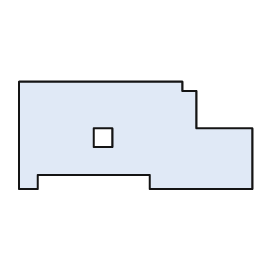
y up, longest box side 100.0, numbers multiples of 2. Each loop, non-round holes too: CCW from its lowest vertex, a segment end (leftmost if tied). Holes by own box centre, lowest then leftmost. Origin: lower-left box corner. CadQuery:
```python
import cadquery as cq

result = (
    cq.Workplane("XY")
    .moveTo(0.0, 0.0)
    .lineTo(8.0, 0.0)
    .lineTo(8.0, 6.0)
    .lineTo(56.0, 6.0)
    .lineTo(56.0, 0.0)
    .lineTo(100.0, 0.0)
    .lineTo(100.0, 26.0)
    .lineTo(76.0, 26.0)
    .lineTo(76.0, 42.0)
    .lineTo(70.0, 42.0)
    .lineTo(70.0, 46.0)
    .lineTo(0.0, 46.0)
    .close()
    .moveTo(32.0, 18.0)
    .lineTo(40.0, 18.0)
    .lineTo(40.0, 26.0)
    .lineTo(32.0, 26.0)
    .close()
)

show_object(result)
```